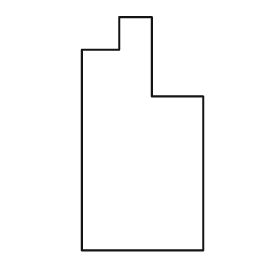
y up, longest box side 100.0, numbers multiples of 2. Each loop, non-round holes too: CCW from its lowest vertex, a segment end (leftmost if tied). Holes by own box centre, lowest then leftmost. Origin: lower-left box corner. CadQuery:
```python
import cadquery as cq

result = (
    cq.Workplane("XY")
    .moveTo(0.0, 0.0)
    .lineTo(52.0, 0.0)
    .lineTo(52.0, 66.0)
    .lineTo(30.0, 66.0)
    .lineTo(30.0, 100.0)
    .lineTo(16.0, 100.0)
    .lineTo(16.0, 86.0)
    .lineTo(0.0, 86.0)
    .close()
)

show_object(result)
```